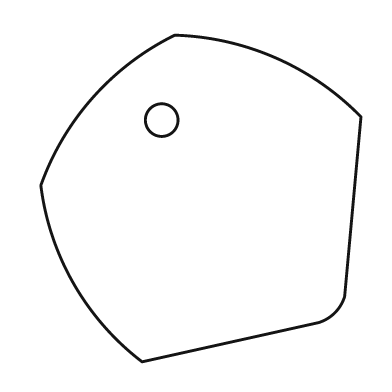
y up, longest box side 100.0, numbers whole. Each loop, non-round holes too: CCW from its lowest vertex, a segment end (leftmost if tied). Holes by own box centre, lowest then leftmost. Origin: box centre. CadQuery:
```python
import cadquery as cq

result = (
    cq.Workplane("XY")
    .moveTo(-18.0, -50.0)
    .lineTo(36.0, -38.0)
    .threePointArc((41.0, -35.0), (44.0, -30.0))
    .lineTo(49.0, 25.0)
    .threePointArc((23.0, 43.0), (-8.0, 50.0))
    .threePointArc((-33.0, 31.0), (-49.0, 4.0))
    .threePointArc((-39.0, -26.0), (-18.0, -50.0))
    .close()
    .moveTo(-12.0, 24.0)
    .circle(5.0)
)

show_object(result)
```